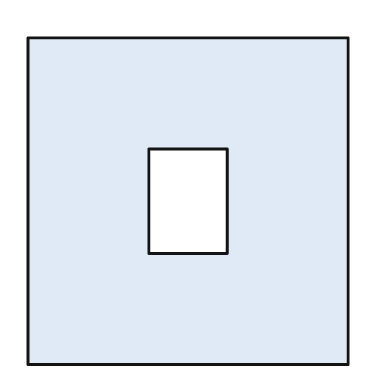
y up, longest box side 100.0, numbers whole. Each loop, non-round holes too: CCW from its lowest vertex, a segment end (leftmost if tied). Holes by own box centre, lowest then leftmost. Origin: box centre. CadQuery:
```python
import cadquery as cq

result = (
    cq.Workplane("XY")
    .moveTo(-49.0, -50.0)
    .lineTo(49.0, -50.0)
    .lineTo(49.0, 50.0)
    .lineTo(-49.0, 50.0)
    .close()
    .moveTo(-12.0, -16.0)
    .lineTo(12.0, -16.0)
    .lineTo(12.0, 16.0)
    .lineTo(-12.0, 16.0)
    .close()
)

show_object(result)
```